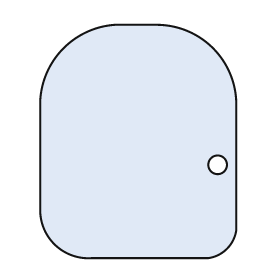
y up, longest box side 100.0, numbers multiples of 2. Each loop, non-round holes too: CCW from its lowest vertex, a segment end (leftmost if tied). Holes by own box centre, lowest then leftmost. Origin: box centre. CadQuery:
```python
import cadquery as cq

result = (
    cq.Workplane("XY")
    .moveTo(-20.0, -50.0)
    .lineTo(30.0, -50.0)
    .threePointArc((38.0, -46.0), (42.0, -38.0))
    .lineTo(42.0, 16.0)
    .threePointArc((32.0, 40.0), (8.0, 50.0))
    .lineTo(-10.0, 50.0)
    .threePointArc((-32.0, 40.0), (-42.0, 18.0))
    .lineTo(-42.0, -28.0)
    .threePointArc((-36.0, -44.0), (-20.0, -50.0))
    .close()
    .moveTo(34.0, -10.0)
    .circle(4.0)
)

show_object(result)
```